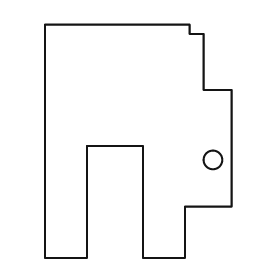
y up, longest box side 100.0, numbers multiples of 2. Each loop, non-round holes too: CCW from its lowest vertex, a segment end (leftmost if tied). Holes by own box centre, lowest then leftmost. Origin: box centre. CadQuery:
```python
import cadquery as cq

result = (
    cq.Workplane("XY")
    .moveTo(-40.0, -50.0)
    .lineTo(-22.0, -50.0)
    .lineTo(-22.0, -2.0)
    .lineTo(2.0, -2.0)
    .lineTo(2.0, -50.0)
    .lineTo(20.0, -50.0)
    .lineTo(20.0, -28.0)
    .lineTo(40.0, -28.0)
    .lineTo(40.0, 22.0)
    .lineTo(28.0, 22.0)
    .lineTo(28.0, 46.0)
    .lineTo(22.0, 46.0)
    .lineTo(22.0, 50.0)
    .lineTo(-40.0, 50.0)
    .close()
    .moveTo(32.0, -8.0)
    .circle(4.0)
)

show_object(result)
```